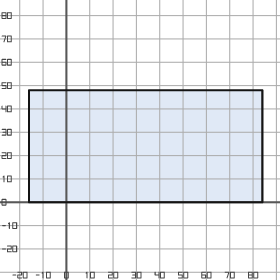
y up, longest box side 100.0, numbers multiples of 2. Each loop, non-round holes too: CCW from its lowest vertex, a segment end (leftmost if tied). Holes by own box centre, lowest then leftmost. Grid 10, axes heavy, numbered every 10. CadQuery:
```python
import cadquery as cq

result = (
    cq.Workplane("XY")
    .moveTo(-16.0, 0.0)
    .lineTo(84.0, 0.0)
    .lineTo(84.0, 48.0)
    .lineTo(-16.0, 48.0)
    .close()
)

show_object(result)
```